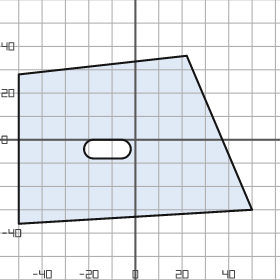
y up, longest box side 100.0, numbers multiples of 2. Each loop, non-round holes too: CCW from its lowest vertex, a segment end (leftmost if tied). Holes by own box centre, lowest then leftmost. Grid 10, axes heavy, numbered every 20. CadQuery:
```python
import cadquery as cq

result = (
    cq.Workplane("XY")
    .moveTo(-50.0, -36.0)
    .lineTo(50.0, -30.0)
    .lineTo(22.0, 36.0)
    .lineTo(-50.0, 28.0)
    .close()
    .moveTo(-18.0, -8.0)
    .lineTo(-6.0, -8.0)
    .threePointArc((-2.0, -4.0), (-6.0, 0.0))
    .lineTo(-18.0, 0.0)
    .threePointArc((-22.0, -4.0), (-18.0, -8.0))
    .close()
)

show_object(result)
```